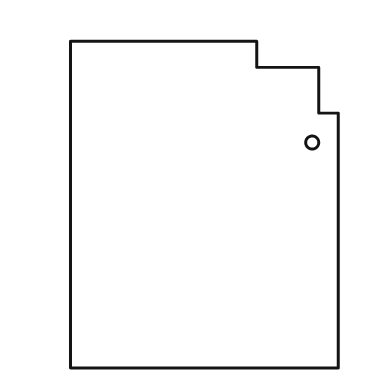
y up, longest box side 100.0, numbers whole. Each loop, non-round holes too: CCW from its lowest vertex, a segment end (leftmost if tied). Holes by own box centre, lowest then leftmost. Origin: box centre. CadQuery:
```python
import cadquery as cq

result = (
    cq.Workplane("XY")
    .moveTo(-41.0, -50.0)
    .lineTo(41.0, -50.0)
    .lineTo(41.0, 28.0)
    .lineTo(35.0, 28.0)
    .lineTo(35.0, 42.0)
    .lineTo(16.0, 42.0)
    .lineTo(16.0, 50.0)
    .lineTo(-41.0, 50.0)
    .close()
    .moveTo(33.0, 19.0)
    .circle(2.0)
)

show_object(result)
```